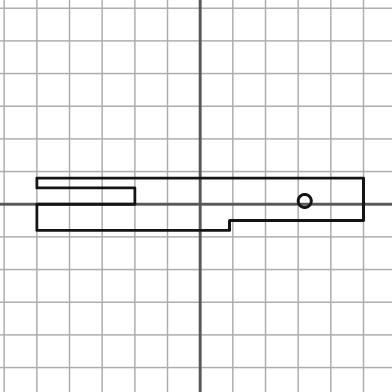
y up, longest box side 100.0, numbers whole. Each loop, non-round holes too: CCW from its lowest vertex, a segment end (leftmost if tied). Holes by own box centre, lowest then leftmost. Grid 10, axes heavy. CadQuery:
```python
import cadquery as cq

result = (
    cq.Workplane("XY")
    .moveTo(-50.0, -8.0)
    .lineTo(9.0, -8.0)
    .lineTo(9.0, -5.0)
    .lineTo(50.0, -5.0)
    .lineTo(50.0, 8.0)
    .lineTo(-50.0, 8.0)
    .lineTo(-50.0, 5.0)
    .lineTo(-20.0, 5.0)
    .lineTo(-20.0, 0.0)
    .lineTo(-50.0, 0.0)
    .close()
    .moveTo(32.0, 1.0)
    .circle(2.0)
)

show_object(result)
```